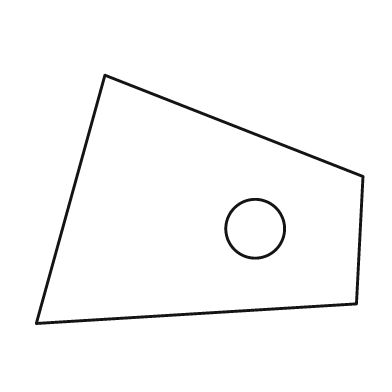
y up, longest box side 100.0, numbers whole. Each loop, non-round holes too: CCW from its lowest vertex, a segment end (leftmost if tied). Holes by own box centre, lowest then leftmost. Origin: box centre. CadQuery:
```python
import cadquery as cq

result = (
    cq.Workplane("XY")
    .moveTo(-50.0, -38.0)
    .lineTo(48.0, -32.0)
    .lineTo(50.0, 7.0)
    .lineTo(-29.0, 38.0)
    .close()
    .moveTo(17.0, -9.0)
    .circle(9.0)
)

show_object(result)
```